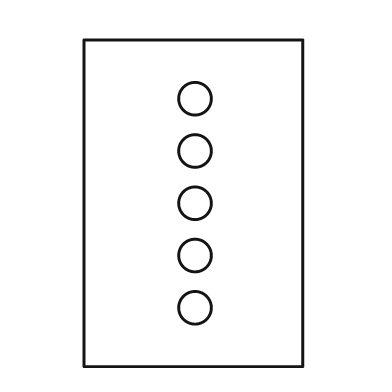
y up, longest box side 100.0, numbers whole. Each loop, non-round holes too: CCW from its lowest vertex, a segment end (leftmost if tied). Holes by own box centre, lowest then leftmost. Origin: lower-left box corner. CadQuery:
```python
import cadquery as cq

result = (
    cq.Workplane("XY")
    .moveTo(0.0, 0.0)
    .lineTo(67.0, 0.0)
    .lineTo(67.0, 100.0)
    .lineTo(0.0, 100.0)
    .close()
    .moveTo(34.0, 18.0)
    .circle(5.0)
    .moveTo(34.0, 34.0)
    .circle(5.0)
    .moveTo(34.0, 50.0)
    .circle(5.0)
    .moveTo(34.0, 66.0)
    .circle(5.0)
    .moveTo(34.0, 82.0)
    .circle(5.0)
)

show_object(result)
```